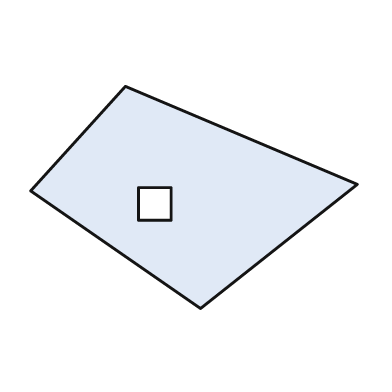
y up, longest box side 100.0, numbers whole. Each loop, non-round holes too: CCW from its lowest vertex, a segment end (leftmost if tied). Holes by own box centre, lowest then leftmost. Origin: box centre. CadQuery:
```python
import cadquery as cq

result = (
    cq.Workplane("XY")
    .moveTo(2.0, -34.0)
    .lineTo(50.0, 4.0)
    .lineTo(-21.0, 34.0)
    .lineTo(-50.0, 2.0)
    .close()
    .moveTo(-17.0, -7.0)
    .lineTo(-7.0, -7.0)
    .lineTo(-7.0, 3.0)
    .lineTo(-17.0, 3.0)
    .close()
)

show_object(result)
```